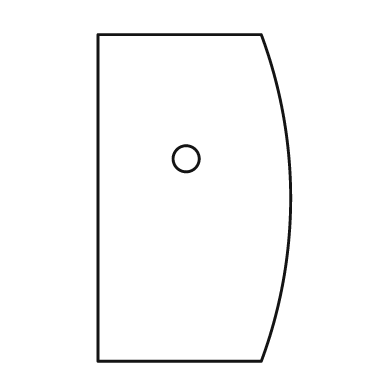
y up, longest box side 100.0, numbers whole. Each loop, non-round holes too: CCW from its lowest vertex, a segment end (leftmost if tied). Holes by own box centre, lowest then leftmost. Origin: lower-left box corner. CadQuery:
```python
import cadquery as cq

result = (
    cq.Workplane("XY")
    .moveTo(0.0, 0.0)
    .lineTo(50.0, 0.0)
    .threePointArc((59.0, 50.0), (50.0, 100.0))
    .lineTo(0.0, 100.0)
    .close()
    .moveTo(27.0, 62.0)
    .circle(4.0)
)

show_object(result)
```